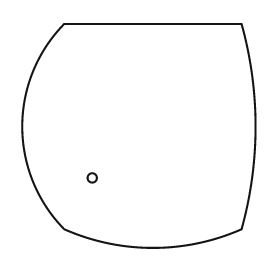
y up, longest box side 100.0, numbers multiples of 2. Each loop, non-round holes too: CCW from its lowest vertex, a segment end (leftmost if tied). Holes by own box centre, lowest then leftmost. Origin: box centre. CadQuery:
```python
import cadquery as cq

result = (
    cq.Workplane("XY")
    .moveTo(-32.0, -40.0)
    .threePointArc((6.0, -48.0), (44.0, -40.0))
    .threePointArc((50.0, 4.0), (44.0, 48.0))
    .lineTo(-32.0, 48.0)
    .threePointArc((-50.0, 4.0), (-32.0, -40.0))
    .close()
    .moveTo(-20.0, -18.0)
    .circle(2.0)
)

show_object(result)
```